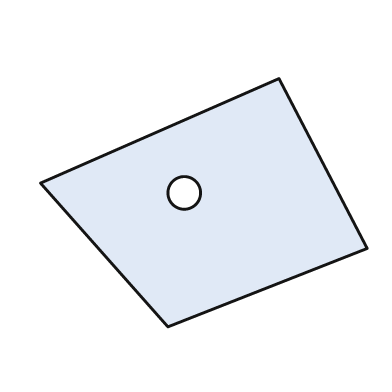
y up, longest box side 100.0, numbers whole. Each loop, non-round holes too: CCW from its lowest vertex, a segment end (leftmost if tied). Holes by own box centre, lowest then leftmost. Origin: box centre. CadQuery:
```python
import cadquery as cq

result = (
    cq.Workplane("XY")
    .moveTo(-11.0, -38.0)
    .lineTo(50.0, -14.0)
    .lineTo(23.0, 38.0)
    .lineTo(-50.0, 6.0)
    .close()
    .moveTo(-6.0, 3.0)
    .circle(5.0)
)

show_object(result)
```